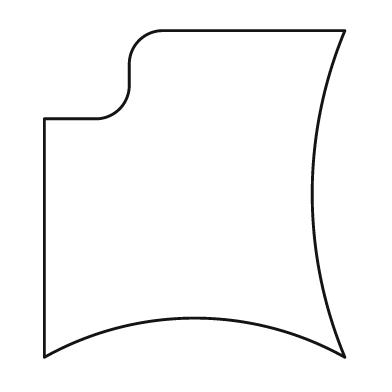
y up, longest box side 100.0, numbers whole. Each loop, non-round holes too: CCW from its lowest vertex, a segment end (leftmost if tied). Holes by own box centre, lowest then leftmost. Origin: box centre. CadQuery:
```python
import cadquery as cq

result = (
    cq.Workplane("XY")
    .moveTo(-46.0, -50.0)
    .threePointArc((0.0, -38.0), (46.0, -50.0))
    .threePointArc((36.0, 0.0), (46.0, 50.0))
    .lineTo(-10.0, 50.0)
    .threePointArc((-17.0, 47.0), (-20.0, 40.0))
    .lineTo(-20.0, 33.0)
    .threePointArc((-23.0, 26.0), (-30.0, 23.0))
    .lineTo(-46.0, 23.0)
    .close()
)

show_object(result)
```